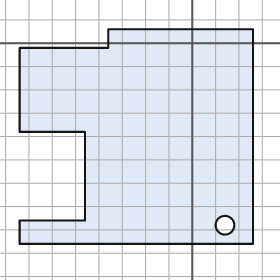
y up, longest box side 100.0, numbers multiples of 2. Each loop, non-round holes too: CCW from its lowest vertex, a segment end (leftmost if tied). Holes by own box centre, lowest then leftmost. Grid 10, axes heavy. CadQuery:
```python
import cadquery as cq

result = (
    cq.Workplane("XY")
    .moveTo(-74.0, -86.0)
    .lineTo(26.0, -86.0)
    .lineTo(26.0, 6.0)
    .lineTo(-36.0, 6.0)
    .lineTo(-36.0, -2.0)
    .lineTo(-74.0, -2.0)
    .lineTo(-74.0, -38.0)
    .lineTo(-46.0, -38.0)
    .lineTo(-46.0, -76.0)
    .lineTo(-74.0, -76.0)
    .close()
    .moveTo(14.0, -78.0)
    .circle(4.0)
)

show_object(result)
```